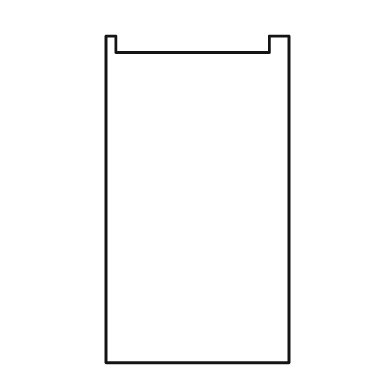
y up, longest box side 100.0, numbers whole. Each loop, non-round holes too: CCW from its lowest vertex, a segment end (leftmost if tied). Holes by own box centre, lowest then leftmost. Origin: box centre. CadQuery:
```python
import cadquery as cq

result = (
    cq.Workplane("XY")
    .moveTo(-28.0, -50.0)
    .lineTo(28.0, -50.0)
    .lineTo(28.0, 50.0)
    .lineTo(22.0, 50.0)
    .lineTo(22.0, 45.0)
    .lineTo(-25.0, 45.0)
    .lineTo(-25.0, 50.0)
    .lineTo(-28.0, 50.0)
    .close()
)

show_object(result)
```